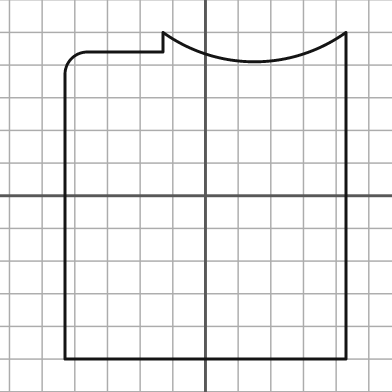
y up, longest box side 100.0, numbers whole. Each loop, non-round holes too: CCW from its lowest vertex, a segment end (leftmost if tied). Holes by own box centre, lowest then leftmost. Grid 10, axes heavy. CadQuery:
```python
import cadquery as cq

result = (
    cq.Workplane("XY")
    .moveTo(-43.0, -50.0)
    .lineTo(43.0, -50.0)
    .lineTo(43.0, 50.0)
    .threePointArc((15.0, 41.0), (-13.0, 50.0))
    .lineTo(-13.0, 44.0)
    .lineTo(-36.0, 44.0)
    .threePointArc((-41.0, 42.0), (-43.0, 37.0))
    .close()
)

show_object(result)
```